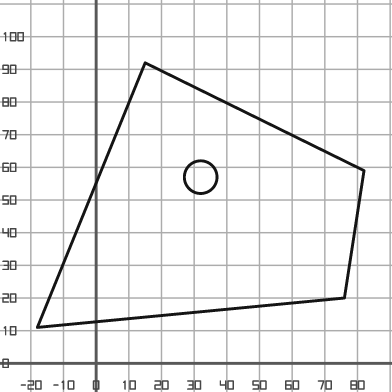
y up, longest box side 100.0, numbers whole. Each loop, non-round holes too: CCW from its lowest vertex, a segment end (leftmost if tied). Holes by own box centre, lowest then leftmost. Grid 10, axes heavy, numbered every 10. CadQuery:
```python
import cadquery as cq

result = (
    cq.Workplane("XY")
    .moveTo(-18.0, 11.0)
    .lineTo(76.0, 20.0)
    .lineTo(82.0, 59.0)
    .lineTo(15.0, 92.0)
    .close()
    .moveTo(32.0, 57.0)
    .circle(5.0)
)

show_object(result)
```